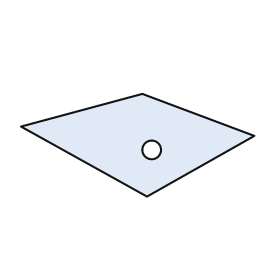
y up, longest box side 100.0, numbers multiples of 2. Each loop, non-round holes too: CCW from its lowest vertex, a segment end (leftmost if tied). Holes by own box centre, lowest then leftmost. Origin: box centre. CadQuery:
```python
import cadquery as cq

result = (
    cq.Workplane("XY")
    .moveTo(4.0, -22.0)
    .lineTo(50.0, 4.0)
    .lineTo(2.0, 22.0)
    .lineTo(-50.0, 8.0)
    .close()
    .moveTo(6.0, -2.0)
    .circle(4.0)
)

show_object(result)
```